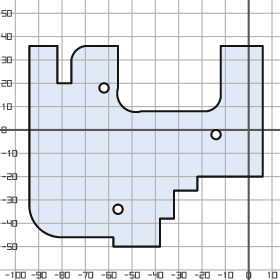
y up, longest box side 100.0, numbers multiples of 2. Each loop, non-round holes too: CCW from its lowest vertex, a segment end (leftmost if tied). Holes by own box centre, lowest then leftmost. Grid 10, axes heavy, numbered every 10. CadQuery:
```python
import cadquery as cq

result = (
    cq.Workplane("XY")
    .moveTo(-58.0, -50.0)
    .lineTo(-38.0, -50.0)
    .lineTo(-38.0, -38.0)
    .lineTo(-32.0, -38.0)
    .lineTo(-32.0, -26.0)
    .lineTo(-22.0, -26.0)
    .lineTo(-22.0, -20.0)
    .lineTo(6.0, -20.0)
    .lineTo(6.0, 36.0)
    .lineTo(-12.0, 36.0)
    .lineTo(-12.0, 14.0)
    .threePointArc((-14.0, 10.0), (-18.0, 8.0))
    .lineTo(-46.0, 8.0)
    .threePointArc((-54.0, 10.0), (-56.0, 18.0))
    .lineTo(-56.0, 36.0)
    .lineTo(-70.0, 36.0)
    .threePointArc((-74.0, 34.0), (-76.0, 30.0))
    .lineTo(-76.0, 20.0)
    .lineTo(-82.0, 20.0)
    .lineTo(-82.0, 36.0)
    .lineTo(-94.0, 36.0)
    .lineTo(-94.0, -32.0)
    .threePointArc((-90.0, -42.0), (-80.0, -46.0))
    .lineTo(-58.0, -46.0)
    .close()
    .moveTo(-56.0, -34.0)
    .circle(2.0)
    .moveTo(-14.0, -2.0)
    .circle(2.0)
    .moveTo(-62.0, 18.0)
    .circle(2.0)
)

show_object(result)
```